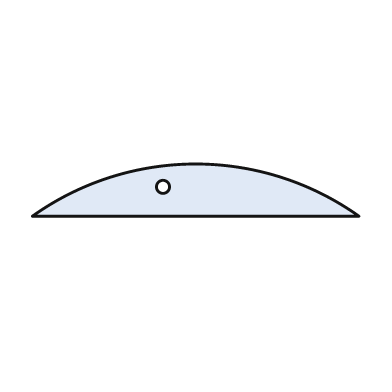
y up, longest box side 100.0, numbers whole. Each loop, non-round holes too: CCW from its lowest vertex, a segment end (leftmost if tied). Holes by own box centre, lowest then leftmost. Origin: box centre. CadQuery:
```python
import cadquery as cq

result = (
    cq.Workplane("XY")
    .moveTo(-50.0, -8.0)
    .lineTo(50.0, -8.0)
    .threePointArc((0.0, 8.0), (-50.0, -8.0))
    .close()
    .moveTo(-10.0, 1.0)
    .circle(2.0)
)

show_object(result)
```